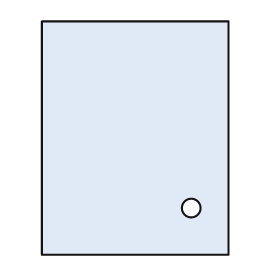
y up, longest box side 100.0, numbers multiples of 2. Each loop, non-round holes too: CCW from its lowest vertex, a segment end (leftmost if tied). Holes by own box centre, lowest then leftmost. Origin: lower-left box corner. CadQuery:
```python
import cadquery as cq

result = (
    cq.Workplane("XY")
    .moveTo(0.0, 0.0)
    .lineTo(80.0, 0.0)
    .lineTo(80.0, 100.0)
    .lineTo(0.0, 100.0)
    .close()
    .moveTo(64.0, 20.0)
    .circle(4.0)
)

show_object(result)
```